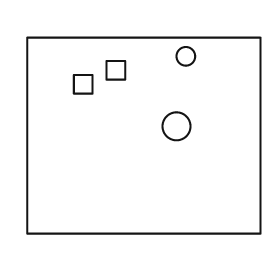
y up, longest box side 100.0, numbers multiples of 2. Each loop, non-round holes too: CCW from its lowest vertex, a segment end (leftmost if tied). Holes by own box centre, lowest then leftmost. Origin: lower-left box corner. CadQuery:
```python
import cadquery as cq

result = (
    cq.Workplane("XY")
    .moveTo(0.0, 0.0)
    .lineTo(100.0, 0.0)
    .lineTo(100.0, 84.0)
    .lineTo(0.0, 84.0)
    .close()
    .moveTo(64.0, 46.0)
    .circle(6.0)
    .moveTo(20.0, 60.0)
    .lineTo(28.0, 60.0)
    .lineTo(28.0, 68.0)
    .lineTo(20.0, 68.0)
    .close()
    .moveTo(34.0, 66.0)
    .lineTo(42.0, 66.0)
    .lineTo(42.0, 74.0)
    .lineTo(34.0, 74.0)
    .close()
    .moveTo(68.0, 76.0)
    .circle(4.0)
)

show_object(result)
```